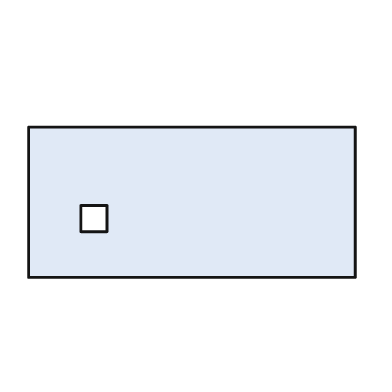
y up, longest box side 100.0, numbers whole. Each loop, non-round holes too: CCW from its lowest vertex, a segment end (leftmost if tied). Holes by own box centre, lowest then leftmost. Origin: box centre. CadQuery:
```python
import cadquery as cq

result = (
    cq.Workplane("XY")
    .moveTo(-50.0, -23.0)
    .lineTo(50.0, -23.0)
    .lineTo(50.0, 23.0)
    .lineTo(-50.0, 23.0)
    .close()
    .moveTo(-34.0, -9.0)
    .lineTo(-26.0, -9.0)
    .lineTo(-26.0, -1.0)
    .lineTo(-34.0, -1.0)
    .close()
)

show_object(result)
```